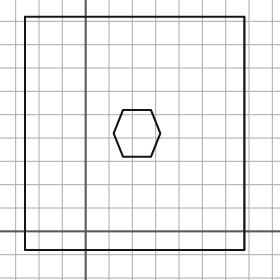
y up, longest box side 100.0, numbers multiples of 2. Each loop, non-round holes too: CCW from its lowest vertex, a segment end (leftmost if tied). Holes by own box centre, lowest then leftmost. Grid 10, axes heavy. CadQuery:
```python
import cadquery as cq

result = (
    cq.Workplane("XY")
    .moveTo(-26.0, -8.0)
    .lineTo(68.0, -8.0)
    .lineTo(68.0, 92.0)
    .lineTo(-26.0, 92.0)
    .close()
    .moveTo(16.0, 32.0)
    .lineTo(28.0, 32.0)
    .lineTo(32.0, 42.0)
    .lineTo(28.0, 52.0)
    .lineTo(16.0, 52.0)
    .lineTo(12.0, 42.0)
    .close()
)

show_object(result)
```